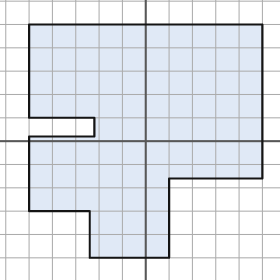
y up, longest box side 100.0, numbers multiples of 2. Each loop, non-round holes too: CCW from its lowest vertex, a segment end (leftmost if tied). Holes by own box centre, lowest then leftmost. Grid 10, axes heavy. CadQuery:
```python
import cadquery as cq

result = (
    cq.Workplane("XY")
    .moveTo(-24.0, -50.0)
    .lineTo(10.0, -50.0)
    .lineTo(10.0, -16.0)
    .lineTo(50.0, -16.0)
    .lineTo(50.0, 50.0)
    .lineTo(-50.0, 50.0)
    .lineTo(-50.0, 10.0)
    .lineTo(-22.0, 10.0)
    .lineTo(-22.0, 2.0)
    .lineTo(-50.0, 2.0)
    .lineTo(-50.0, -30.0)
    .lineTo(-24.0, -30.0)
    .close()
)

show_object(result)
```